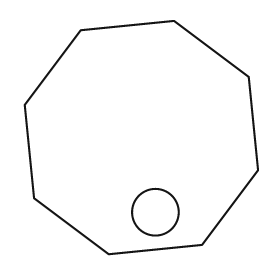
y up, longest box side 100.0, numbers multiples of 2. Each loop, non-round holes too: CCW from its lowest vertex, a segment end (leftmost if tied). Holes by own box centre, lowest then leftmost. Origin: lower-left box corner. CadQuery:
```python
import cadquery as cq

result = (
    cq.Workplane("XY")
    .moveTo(36.0, 0.0)
    .lineTo(76.0, 4.0)
    .lineTo(100.0, 36.0)
    .lineTo(96.0, 76.0)
    .lineTo(64.0, 100.0)
    .lineTo(24.0, 96.0)
    .lineTo(0.0, 64.0)
    .lineTo(4.0, 24.0)
    .close()
    .moveTo(56.0, 18.0)
    .circle(10.0)
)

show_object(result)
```